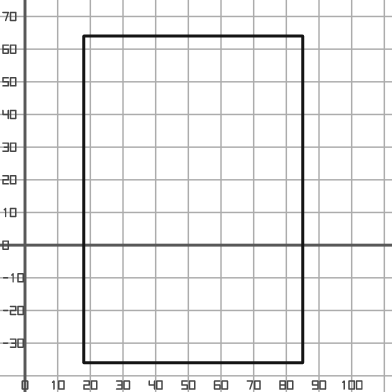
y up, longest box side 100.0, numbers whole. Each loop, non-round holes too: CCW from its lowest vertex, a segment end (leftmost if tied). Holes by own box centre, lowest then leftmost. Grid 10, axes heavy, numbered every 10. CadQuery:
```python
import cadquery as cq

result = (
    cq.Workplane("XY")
    .moveTo(18.0, -36.0)
    .lineTo(85.0, -36.0)
    .lineTo(85.0, 64.0)
    .lineTo(18.0, 64.0)
    .close()
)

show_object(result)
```